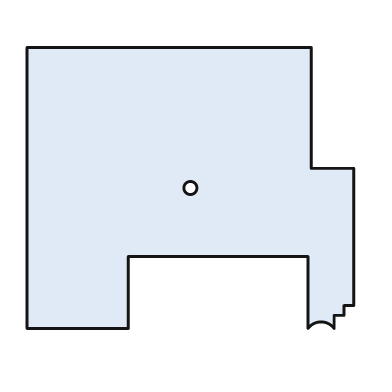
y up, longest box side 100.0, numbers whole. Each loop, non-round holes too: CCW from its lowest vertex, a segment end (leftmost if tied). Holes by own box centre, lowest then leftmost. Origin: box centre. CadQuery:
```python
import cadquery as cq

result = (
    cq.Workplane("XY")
    .moveTo(-50.0, -43.0)
    .lineTo(-19.0, -43.0)
    .lineTo(-19.0, -21.0)
    .lineTo(36.0, -21.0)
    .lineTo(36.0, -43.0)
    .threePointArc((40.0, -41.0), (44.0, -43.0))
    .lineTo(44.0, -39.0)
    .lineTo(47.0, -39.0)
    .lineTo(47.0, -36.0)
    .lineTo(50.0, -36.0)
    .lineTo(50.0, 6.0)
    .lineTo(37.0, 6.0)
    .lineTo(37.0, 43.0)
    .lineTo(-50.0, 43.0)
    .close()
    .moveTo(0.0, 0.0)
    .circle(2.0)
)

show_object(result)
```